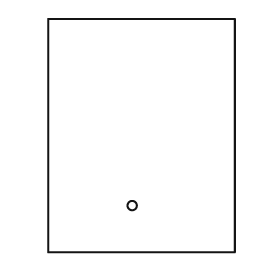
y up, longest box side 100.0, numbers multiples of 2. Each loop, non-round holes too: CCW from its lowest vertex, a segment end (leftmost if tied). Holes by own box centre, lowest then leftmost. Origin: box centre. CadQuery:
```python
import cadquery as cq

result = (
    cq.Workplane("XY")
    .moveTo(-40.0, -50.0)
    .lineTo(40.0, -50.0)
    .lineTo(40.0, 50.0)
    .lineTo(-40.0, 50.0)
    .close()
    .moveTo(-4.0, -30.0)
    .circle(2.0)
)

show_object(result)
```